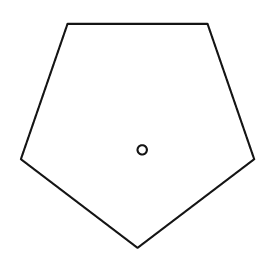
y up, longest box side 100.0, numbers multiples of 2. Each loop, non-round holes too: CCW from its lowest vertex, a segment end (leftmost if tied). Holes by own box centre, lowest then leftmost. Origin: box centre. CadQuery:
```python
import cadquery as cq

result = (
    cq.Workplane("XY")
    .moveTo(0.0, -48.0)
    .lineTo(50.0, -10.0)
    .lineTo(30.0, 48.0)
    .lineTo(-30.0, 48.0)
    .lineTo(-50.0, -10.0)
    .close()
    .moveTo(2.0, -6.0)
    .circle(2.0)
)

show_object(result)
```